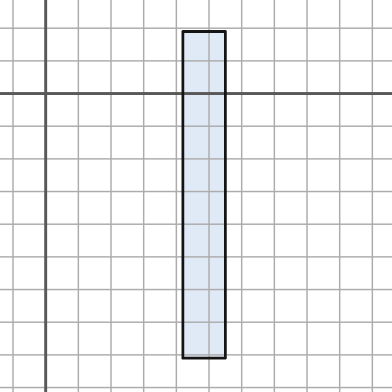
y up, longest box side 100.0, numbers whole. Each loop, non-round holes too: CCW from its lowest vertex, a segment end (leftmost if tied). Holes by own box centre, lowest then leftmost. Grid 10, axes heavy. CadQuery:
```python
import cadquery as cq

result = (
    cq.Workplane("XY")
    .moveTo(42.0, -81.0)
    .lineTo(55.0, -81.0)
    .lineTo(55.0, 19.0)
    .lineTo(42.0, 19.0)
    .close()
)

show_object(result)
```